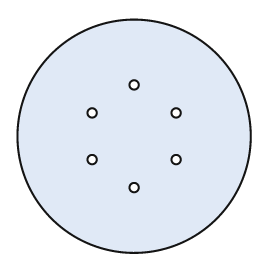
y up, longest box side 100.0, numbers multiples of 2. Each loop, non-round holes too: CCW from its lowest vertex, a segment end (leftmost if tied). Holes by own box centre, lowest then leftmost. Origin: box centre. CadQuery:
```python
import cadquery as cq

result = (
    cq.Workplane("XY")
    .moveTo(0.0, 0.0)
    .circle(50.0)
    .moveTo(0.0, -22.0)
    .circle(2.0)
    .moveTo(-18.0, -10.0)
    .circle(2.0)
    .moveTo(18.0, -10.0)
    .circle(2.0)
    .moveTo(-18.0, 10.0)
    .circle(2.0)
    .moveTo(18.0, 10.0)
    .circle(2.0)
    .moveTo(0.0, 22.0)
    .circle(2.0)
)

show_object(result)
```